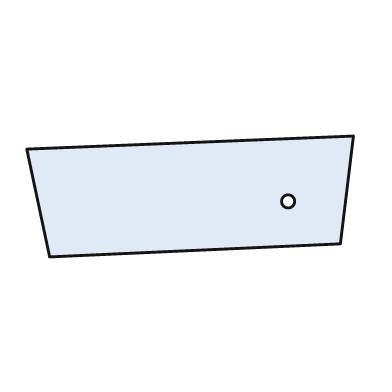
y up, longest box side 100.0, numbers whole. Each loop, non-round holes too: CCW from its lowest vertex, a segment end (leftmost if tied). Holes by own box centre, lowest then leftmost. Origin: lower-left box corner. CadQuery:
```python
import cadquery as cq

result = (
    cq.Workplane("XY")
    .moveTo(7.0, 0.0)
    .lineTo(96.0, 4.0)
    .lineTo(100.0, 37.0)
    .lineTo(0.0, 33.0)
    .close()
    .moveTo(80.0, 17.0)
    .circle(2.0)
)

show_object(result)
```